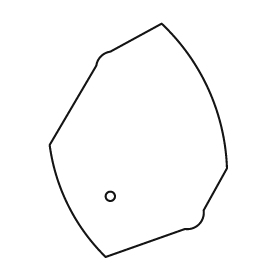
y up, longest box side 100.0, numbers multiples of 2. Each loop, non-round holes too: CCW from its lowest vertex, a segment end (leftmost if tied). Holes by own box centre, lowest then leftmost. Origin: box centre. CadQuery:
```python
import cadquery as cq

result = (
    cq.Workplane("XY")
    .moveTo(-14.0, -50.0)
    .lineTo(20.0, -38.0)
    .threePointArc((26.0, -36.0), (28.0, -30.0))
    .lineTo(38.0, -12.0)
    .threePointArc((30.0, 22.0), (10.0, 50.0))
    .lineTo(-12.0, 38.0)
    .threePointArc((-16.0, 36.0), (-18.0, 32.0))
    .lineTo(-38.0, -2.0)
    .threePointArc((-30.0, -28.0), (-14.0, -50.0))
    .close()
    .moveTo(-12.0, -24.0)
    .circle(2.0)
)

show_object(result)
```